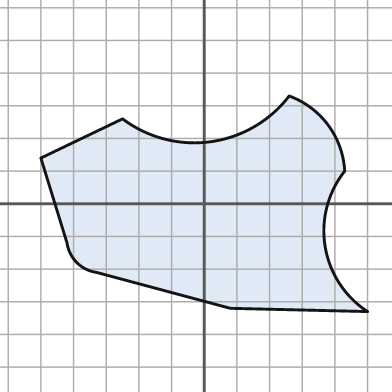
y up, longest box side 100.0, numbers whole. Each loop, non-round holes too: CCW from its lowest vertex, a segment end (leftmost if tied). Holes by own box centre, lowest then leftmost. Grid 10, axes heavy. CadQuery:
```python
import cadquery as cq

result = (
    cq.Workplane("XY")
    .moveTo(50.0, -33.0)
    .threePointArc((37.0, -13.0), (43.0, 10.0))
    .threePointArc((38.0, 24.0), (26.0, 33.0))
    .threePointArc((2.0, 19.0), (-25.0, 26.0))
    .lineTo(-50.0, 14.0)
    .lineTo(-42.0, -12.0)
    .threePointArc((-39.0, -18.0), (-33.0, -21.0))
    .lineTo(8.0, -32.0)
    .close()
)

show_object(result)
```